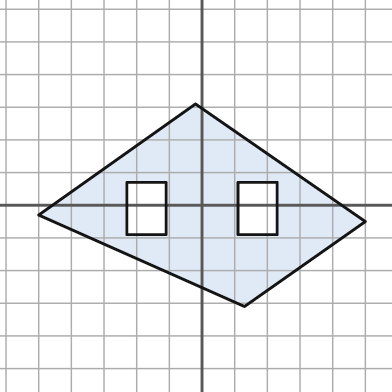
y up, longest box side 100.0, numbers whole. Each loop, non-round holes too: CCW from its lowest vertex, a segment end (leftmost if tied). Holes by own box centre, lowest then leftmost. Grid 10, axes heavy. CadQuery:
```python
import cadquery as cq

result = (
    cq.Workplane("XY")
    .moveTo(13.0, -31.0)
    .lineTo(50.0, -5.0)
    .lineTo(-2.0, 31.0)
    .lineTo(-50.0, -3.0)
    .close()
    .moveTo(-23.0, -9.0)
    .lineTo(-11.0, -9.0)
    .lineTo(-11.0, 7.0)
    .lineTo(-23.0, 7.0)
    .close()
    .moveTo(11.0, -9.0)
    .lineTo(23.0, -9.0)
    .lineTo(23.0, 7.0)
    .lineTo(11.0, 7.0)
    .close()
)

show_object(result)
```